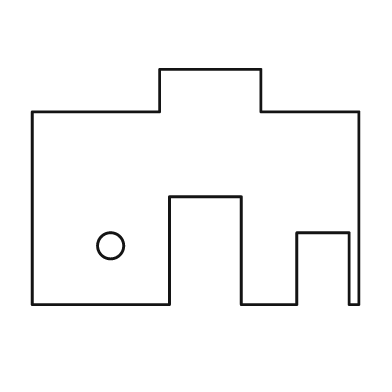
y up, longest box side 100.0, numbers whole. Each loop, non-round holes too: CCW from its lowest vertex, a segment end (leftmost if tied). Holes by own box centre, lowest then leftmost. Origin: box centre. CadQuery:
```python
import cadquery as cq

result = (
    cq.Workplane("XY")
    .moveTo(-50.0, -36.0)
    .lineTo(-8.0, -36.0)
    .lineTo(-8.0, -3.0)
    .lineTo(14.0, -3.0)
    .lineTo(14.0, -36.0)
    .lineTo(31.0, -36.0)
    .lineTo(31.0, -14.0)
    .lineTo(47.0, -14.0)
    .lineTo(47.0, -36.0)
    .lineTo(50.0, -36.0)
    .lineTo(50.0, 23.0)
    .lineTo(20.0, 23.0)
    .lineTo(20.0, 36.0)
    .lineTo(-11.0, 36.0)
    .lineTo(-11.0, 23.0)
    .lineTo(-50.0, 23.0)
    .close()
    .moveTo(-26.0, -18.0)
    .circle(4.0)
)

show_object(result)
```